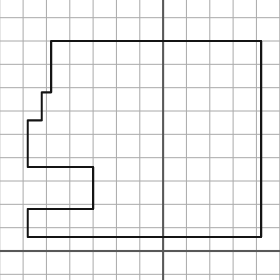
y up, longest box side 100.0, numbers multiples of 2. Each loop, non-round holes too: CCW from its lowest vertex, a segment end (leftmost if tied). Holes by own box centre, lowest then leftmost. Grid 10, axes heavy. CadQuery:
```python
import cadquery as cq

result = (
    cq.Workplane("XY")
    .moveTo(-58.0, 6.0)
    .lineTo(42.0, 6.0)
    .lineTo(42.0, 90.0)
    .lineTo(-48.0, 90.0)
    .lineTo(-48.0, 68.0)
    .lineTo(-52.0, 68.0)
    .lineTo(-52.0, 56.0)
    .lineTo(-58.0, 56.0)
    .lineTo(-58.0, 36.0)
    .lineTo(-30.0, 36.0)
    .lineTo(-30.0, 18.0)
    .lineTo(-58.0, 18.0)
    .close()
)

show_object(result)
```